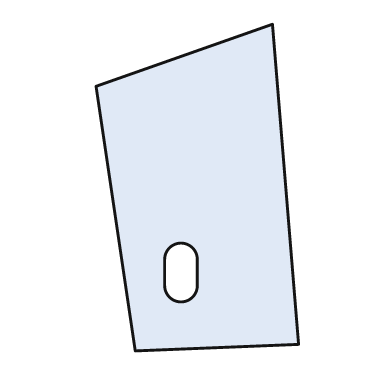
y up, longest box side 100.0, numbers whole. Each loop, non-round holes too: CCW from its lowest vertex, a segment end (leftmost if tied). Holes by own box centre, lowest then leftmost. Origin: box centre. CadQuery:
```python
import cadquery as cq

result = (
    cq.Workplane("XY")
    .moveTo(-19.0, -50.0)
    .lineTo(31.0, -48.0)
    .lineTo(23.0, 50.0)
    .lineTo(-31.0, 31.0)
    .close()
    .moveTo(-10.0, -30.0)
    .threePointArc((-5.0, -35.0), (0.0, -30.0))
    .lineTo(0.0, -22.0)
    .threePointArc((-5.0, -17.0), (-10.0, -22.0))
    .close()
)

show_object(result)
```